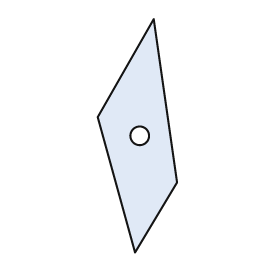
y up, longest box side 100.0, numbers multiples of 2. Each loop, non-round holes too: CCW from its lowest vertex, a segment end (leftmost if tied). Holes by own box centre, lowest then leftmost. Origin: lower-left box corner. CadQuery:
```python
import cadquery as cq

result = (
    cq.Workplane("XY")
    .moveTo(16.0, 0.0)
    .lineTo(34.0, 30.0)
    .lineTo(24.0, 100.0)
    .lineTo(0.0, 58.0)
    .close()
    .moveTo(18.0, 50.0)
    .circle(4.0)
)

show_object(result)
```